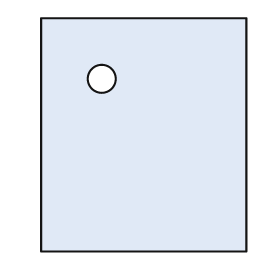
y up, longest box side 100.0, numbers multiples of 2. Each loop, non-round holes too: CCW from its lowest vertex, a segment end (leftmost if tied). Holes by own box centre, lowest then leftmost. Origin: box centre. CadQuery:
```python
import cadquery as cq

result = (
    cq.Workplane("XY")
    .moveTo(-44.0, -50.0)
    .lineTo(44.0, -50.0)
    .lineTo(44.0, 50.0)
    .lineTo(-44.0, 50.0)
    .close()
    .moveTo(-18.0, 24.0)
    .circle(6.0)
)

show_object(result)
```